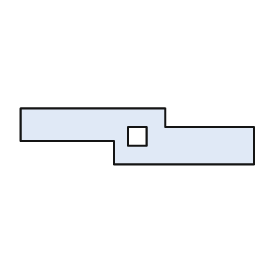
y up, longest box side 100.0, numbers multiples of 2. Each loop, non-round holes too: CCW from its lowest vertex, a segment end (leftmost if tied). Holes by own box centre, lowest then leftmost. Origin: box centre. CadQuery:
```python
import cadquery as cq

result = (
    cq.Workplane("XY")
    .moveTo(-10.0, -12.0)
    .lineTo(50.0, -12.0)
    .lineTo(50.0, 4.0)
    .lineTo(12.0, 4.0)
    .lineTo(12.0, 12.0)
    .lineTo(-50.0, 12.0)
    .lineTo(-50.0, -2.0)
    .lineTo(-10.0, -2.0)
    .close()
    .moveTo(-4.0, -4.0)
    .lineTo(4.0, -4.0)
    .lineTo(4.0, 4.0)
    .lineTo(-4.0, 4.0)
    .close()
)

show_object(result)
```